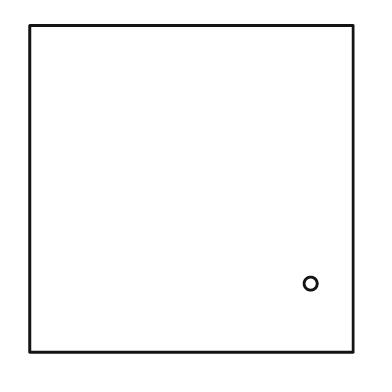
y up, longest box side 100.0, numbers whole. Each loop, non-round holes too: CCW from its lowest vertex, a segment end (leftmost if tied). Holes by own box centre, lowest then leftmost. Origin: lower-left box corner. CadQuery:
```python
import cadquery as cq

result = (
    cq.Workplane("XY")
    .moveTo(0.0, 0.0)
    .lineTo(99.0, 0.0)
    .lineTo(99.0, 100.0)
    .lineTo(0.0, 100.0)
    .close()
    .moveTo(86.0, 21.0)
    .circle(2.0)
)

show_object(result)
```